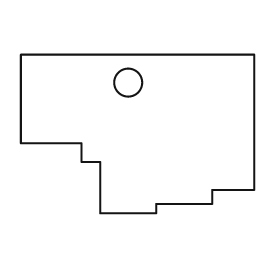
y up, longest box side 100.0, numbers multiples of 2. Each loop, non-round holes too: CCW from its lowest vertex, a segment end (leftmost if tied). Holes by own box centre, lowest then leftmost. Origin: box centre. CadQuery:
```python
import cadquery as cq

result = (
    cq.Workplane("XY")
    .moveTo(-16.0, -34.0)
    .lineTo(8.0, -34.0)
    .lineTo(8.0, -30.0)
    .lineTo(32.0, -30.0)
    .lineTo(32.0, -24.0)
    .lineTo(50.0, -24.0)
    .lineTo(50.0, 34.0)
    .lineTo(-50.0, 34.0)
    .lineTo(-50.0, -4.0)
    .lineTo(-24.0, -4.0)
    .lineTo(-24.0, -12.0)
    .lineTo(-16.0, -12.0)
    .close()
    .moveTo(-4.0, 22.0)
    .circle(6.0)
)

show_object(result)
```